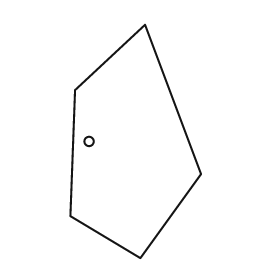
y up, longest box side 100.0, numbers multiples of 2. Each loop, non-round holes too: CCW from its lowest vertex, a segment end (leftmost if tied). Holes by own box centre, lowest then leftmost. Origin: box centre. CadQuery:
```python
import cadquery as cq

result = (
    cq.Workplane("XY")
    .moveTo(2.0, -50.0)
    .lineTo(28.0, -14.0)
    .lineTo(4.0, 50.0)
    .lineTo(-26.0, 22.0)
    .lineTo(-28.0, -32.0)
    .close()
    .moveTo(-20.0, 0.0)
    .circle(2.0)
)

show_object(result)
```